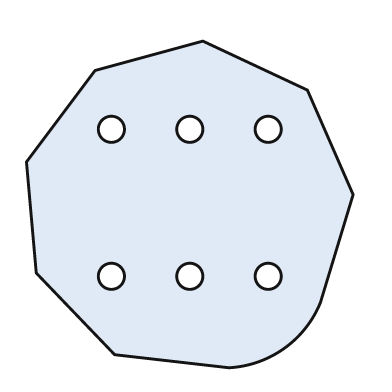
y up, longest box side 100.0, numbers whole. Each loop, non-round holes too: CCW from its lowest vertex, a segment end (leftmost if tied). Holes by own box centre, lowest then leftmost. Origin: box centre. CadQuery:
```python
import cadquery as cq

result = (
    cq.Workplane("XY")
    .moveTo(12.0, -50.0)
    .threePointArc((29.0, -44.0), (40.0, -30.0))
    .lineTo(50.0, 3.0)
    .lineTo(36.0, 35.0)
    .lineTo(4.0, 50.0)
    .lineTo(-29.0, 41.0)
    .lineTo(-50.0, 13.0)
    .lineTo(-47.0, -21.0)
    .lineTo(-23.0, -46.0)
    .close()
    .moveTo(-24.0, -22.0)
    .circle(4.0)
    .moveTo(0.0, -22.0)
    .circle(4.0)
    .moveTo(24.0, -22.0)
    .circle(4.0)
    .moveTo(-24.0, 23.0)
    .circle(4.0)
    .moveTo(0.0, 23.0)
    .circle(4.0)
    .moveTo(24.0, 23.0)
    .circle(4.0)
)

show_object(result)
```